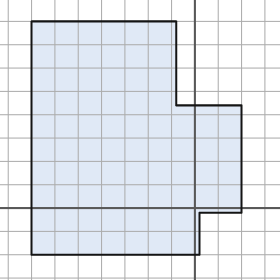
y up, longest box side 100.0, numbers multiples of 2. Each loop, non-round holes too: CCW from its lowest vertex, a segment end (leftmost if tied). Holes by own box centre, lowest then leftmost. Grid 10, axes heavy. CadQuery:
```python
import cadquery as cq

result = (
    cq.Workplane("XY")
    .moveTo(-70.0, -20.0)
    .lineTo(2.0, -20.0)
    .lineTo(2.0, -2.0)
    .lineTo(20.0, -2.0)
    .lineTo(20.0, 44.0)
    .lineTo(-8.0, 44.0)
    .lineTo(-8.0, 80.0)
    .lineTo(-70.0, 80.0)
    .close()
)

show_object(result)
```